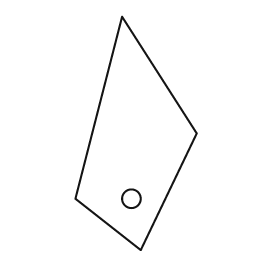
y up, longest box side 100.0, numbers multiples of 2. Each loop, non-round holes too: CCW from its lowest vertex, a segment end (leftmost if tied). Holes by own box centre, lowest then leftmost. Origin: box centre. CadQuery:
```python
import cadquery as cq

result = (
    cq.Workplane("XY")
    .moveTo(2.0, -50.0)
    .lineTo(26.0, 0.0)
    .lineTo(-6.0, 50.0)
    .lineTo(-26.0, -28.0)
    .close()
    .moveTo(-2.0, -28.0)
    .circle(4.0)
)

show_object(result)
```